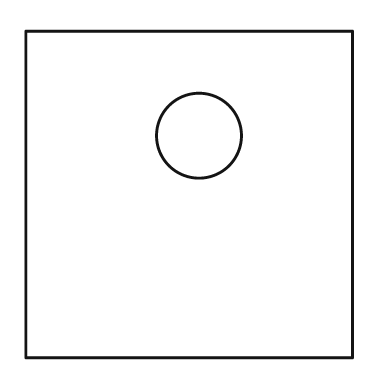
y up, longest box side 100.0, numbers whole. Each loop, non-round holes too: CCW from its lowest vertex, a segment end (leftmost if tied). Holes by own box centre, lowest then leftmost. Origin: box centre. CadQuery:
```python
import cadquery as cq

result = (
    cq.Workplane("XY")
    .moveTo(-50.0, -50.0)
    .lineTo(50.0, -50.0)
    .lineTo(50.0, 50.0)
    .lineTo(-50.0, 50.0)
    .close()
    .moveTo(3.0, 18.0)
    .circle(13.0)
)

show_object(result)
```